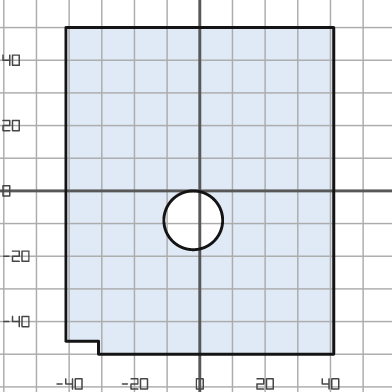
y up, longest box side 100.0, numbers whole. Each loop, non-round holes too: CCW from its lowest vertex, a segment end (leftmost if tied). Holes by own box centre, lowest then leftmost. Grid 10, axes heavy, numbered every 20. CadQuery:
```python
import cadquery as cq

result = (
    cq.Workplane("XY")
    .moveTo(-31.0, -50.0)
    .lineTo(41.0, -50.0)
    .lineTo(41.0, 50.0)
    .lineTo(-41.0, 50.0)
    .lineTo(-41.0, -46.0)
    .lineTo(-31.0, -46.0)
    .close()
    .moveTo(-2.0, -9.0)
    .circle(9.0)
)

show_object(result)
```